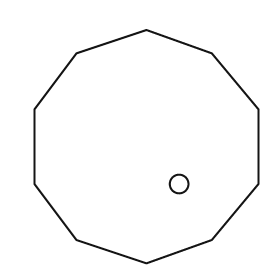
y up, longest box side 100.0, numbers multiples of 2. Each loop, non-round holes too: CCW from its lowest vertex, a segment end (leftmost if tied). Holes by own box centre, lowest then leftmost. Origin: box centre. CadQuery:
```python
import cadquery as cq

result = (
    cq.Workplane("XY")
    .moveTo(0.0, -50.0)
    .lineTo(28.0, -40.0)
    .lineTo(48.0, -16.0)
    .lineTo(48.0, 16.0)
    .lineTo(28.0, 40.0)
    .lineTo(0.0, 50.0)
    .lineTo(-30.0, 40.0)
    .lineTo(-48.0, 16.0)
    .lineTo(-48.0, -16.0)
    .lineTo(-30.0, -40.0)
    .close()
    .moveTo(14.0, -16.0)
    .circle(4.0)
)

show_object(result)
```